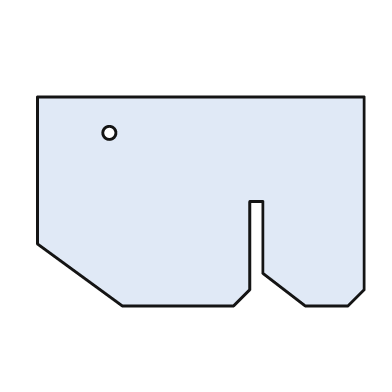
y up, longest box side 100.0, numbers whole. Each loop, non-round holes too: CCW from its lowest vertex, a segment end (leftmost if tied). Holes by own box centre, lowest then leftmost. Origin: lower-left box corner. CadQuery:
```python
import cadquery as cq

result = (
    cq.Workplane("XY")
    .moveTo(26.0, 0.0)
    .lineTo(60.0, 0.0)
    .lineTo(65.0, 5.0)
    .lineTo(65.0, 32.0)
    .lineTo(69.0, 32.0)
    .lineTo(69.0, 10.0)
    .lineTo(82.0, 0.0)
    .lineTo(95.0, 0.0)
    .lineTo(100.0, 5.0)
    .lineTo(100.0, 64.0)
    .lineTo(0.0, 64.0)
    .lineTo(0.0, 19.0)
    .close()
    .moveTo(22.0, 53.0)
    .circle(2.0)
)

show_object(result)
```